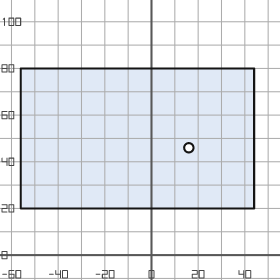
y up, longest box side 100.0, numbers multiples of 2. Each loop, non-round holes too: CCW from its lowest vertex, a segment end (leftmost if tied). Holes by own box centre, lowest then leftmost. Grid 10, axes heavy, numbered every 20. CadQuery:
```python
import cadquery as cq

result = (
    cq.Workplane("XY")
    .moveTo(-56.0, 20.0)
    .lineTo(44.0, 20.0)
    .lineTo(44.0, 80.0)
    .lineTo(-56.0, 80.0)
    .close()
    .moveTo(16.0, 46.0)
    .circle(2.0)
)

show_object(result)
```